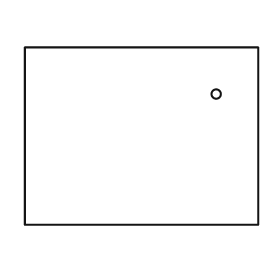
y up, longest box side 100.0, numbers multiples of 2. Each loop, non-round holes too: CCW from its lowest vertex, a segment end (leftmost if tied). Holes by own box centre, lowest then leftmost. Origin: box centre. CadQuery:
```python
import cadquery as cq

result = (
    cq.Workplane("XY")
    .moveTo(-50.0, -38.0)
    .lineTo(50.0, -38.0)
    .lineTo(50.0, 38.0)
    .lineTo(-50.0, 38.0)
    .close()
    .moveTo(32.0, 18.0)
    .circle(2.0)
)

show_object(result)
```